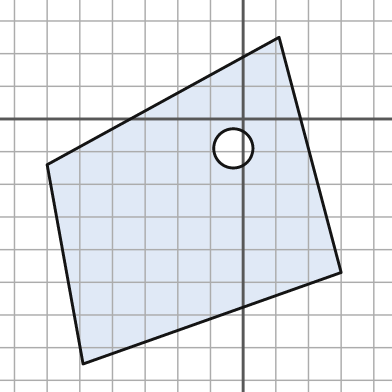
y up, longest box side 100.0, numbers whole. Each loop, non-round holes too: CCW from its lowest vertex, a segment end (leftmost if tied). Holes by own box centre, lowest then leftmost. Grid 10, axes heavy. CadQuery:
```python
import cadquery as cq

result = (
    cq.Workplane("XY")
    .moveTo(-49.0, -75.0)
    .lineTo(30.0, -47.0)
    .lineTo(11.0, 25.0)
    .lineTo(-60.0, -14.0)
    .close()
    .moveTo(-3.0, -9.0)
    .circle(6.0)
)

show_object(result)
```